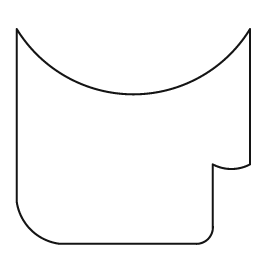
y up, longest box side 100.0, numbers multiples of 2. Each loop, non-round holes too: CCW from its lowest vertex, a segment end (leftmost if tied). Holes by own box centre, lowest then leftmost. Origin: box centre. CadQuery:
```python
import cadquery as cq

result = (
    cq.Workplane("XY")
    .moveTo(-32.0, -46.0)
    .lineTo(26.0, -46.0)
    .threePointArc((32.0, -44.0), (34.0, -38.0))
    .lineTo(34.0, -12.0)
    .threePointArc((42.0, -14.0), (50.0, -12.0))
    .lineTo(50.0, 46.0)
    .threePointArc((0.0, 18.0), (-50.0, 46.0))
    .lineTo(-50.0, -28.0)
    .threePointArc((-44.0, -40.0), (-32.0, -46.0))
    .close()
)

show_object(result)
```